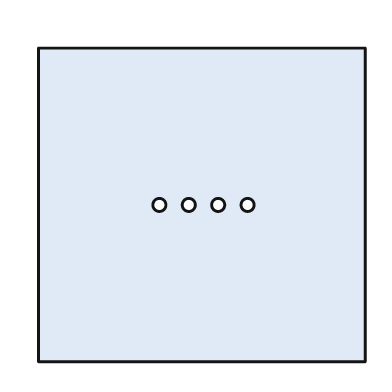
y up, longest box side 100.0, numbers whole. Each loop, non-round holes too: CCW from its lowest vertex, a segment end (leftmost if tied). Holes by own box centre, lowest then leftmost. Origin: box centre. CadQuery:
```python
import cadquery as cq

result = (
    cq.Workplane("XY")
    .moveTo(-50.0, -48.0)
    .lineTo(50.0, -48.0)
    .lineTo(50.0, 48.0)
    .lineTo(-50.0, 48.0)
    .close()
    .moveTo(-13.0, 0.0)
    .circle(2.0)
    .moveTo(-4.0, 0.0)
    .circle(2.0)
    .moveTo(5.0, 0.0)
    .circle(2.0)
    .moveTo(14.0, 0.0)
    .circle(2.0)
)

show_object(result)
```